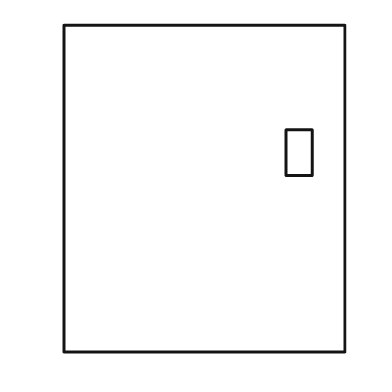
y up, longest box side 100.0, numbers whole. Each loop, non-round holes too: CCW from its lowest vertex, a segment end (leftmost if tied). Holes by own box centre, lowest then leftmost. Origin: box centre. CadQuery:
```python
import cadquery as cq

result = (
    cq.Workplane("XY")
    .moveTo(-43.0, -50.0)
    .lineTo(43.0, -50.0)
    .lineTo(43.0, 50.0)
    .lineTo(-43.0, 50.0)
    .close()
    .moveTo(25.0, 4.0)
    .lineTo(33.0, 4.0)
    .lineTo(33.0, 18.0)
    .lineTo(25.0, 18.0)
    .close()
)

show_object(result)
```